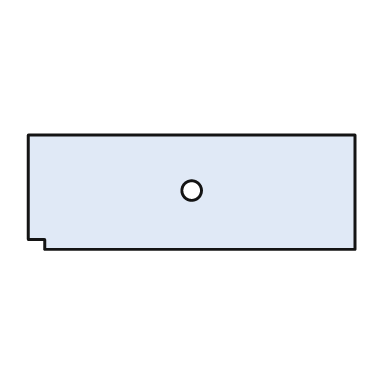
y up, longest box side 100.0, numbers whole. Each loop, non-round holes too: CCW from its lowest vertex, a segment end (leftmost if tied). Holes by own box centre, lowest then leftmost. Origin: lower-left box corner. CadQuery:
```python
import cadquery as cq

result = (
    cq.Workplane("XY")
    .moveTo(5.0, 0.0)
    .lineTo(100.0, 0.0)
    .lineTo(100.0, 35.0)
    .lineTo(0.0, 35.0)
    .lineTo(0.0, 3.0)
    .lineTo(5.0, 3.0)
    .close()
    .moveTo(50.0, 18.0)
    .circle(3.0)
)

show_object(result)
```